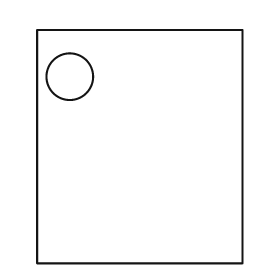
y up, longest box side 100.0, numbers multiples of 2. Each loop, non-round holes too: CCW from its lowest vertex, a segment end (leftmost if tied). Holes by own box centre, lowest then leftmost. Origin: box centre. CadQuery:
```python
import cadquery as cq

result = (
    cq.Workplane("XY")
    .moveTo(-44.0, -50.0)
    .lineTo(44.0, -50.0)
    .lineTo(44.0, 50.0)
    .lineTo(-44.0, 50.0)
    .close()
    .moveTo(-30.0, 30.0)
    .circle(10.0)
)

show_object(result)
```